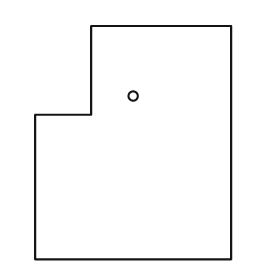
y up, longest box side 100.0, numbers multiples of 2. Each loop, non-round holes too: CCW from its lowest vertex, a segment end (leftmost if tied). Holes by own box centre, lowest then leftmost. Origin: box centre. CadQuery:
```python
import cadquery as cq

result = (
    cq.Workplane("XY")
    .moveTo(-42.0, -50.0)
    .lineTo(42.0, -50.0)
    .lineTo(42.0, 50.0)
    .lineTo(-18.0, 50.0)
    .lineTo(-18.0, 12.0)
    .lineTo(-42.0, 12.0)
    .close()
    .moveTo(0.0, 20.0)
    .circle(2.0)
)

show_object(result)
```